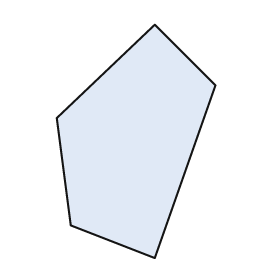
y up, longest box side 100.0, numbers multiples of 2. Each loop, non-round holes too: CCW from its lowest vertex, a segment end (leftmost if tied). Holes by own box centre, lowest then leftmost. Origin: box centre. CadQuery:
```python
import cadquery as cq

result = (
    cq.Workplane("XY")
    .moveTo(8.0, -50.0)
    .lineTo(34.0, 24.0)
    .lineTo(8.0, 50.0)
    .lineTo(-34.0, 10.0)
    .lineTo(-28.0, -36.0)
    .close()
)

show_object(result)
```